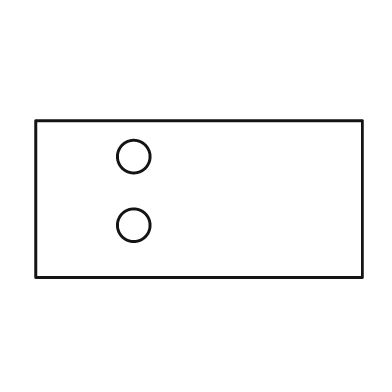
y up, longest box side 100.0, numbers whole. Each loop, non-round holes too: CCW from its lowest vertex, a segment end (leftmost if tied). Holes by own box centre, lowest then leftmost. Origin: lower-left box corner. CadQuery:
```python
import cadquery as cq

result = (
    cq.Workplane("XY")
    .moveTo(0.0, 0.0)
    .lineTo(100.0, 0.0)
    .lineTo(100.0, 48.0)
    .lineTo(0.0, 48.0)
    .close()
    .moveTo(30.0, 16.0)
    .circle(5.0)
    .moveTo(30.0, 37.0)
    .circle(5.0)
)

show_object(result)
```